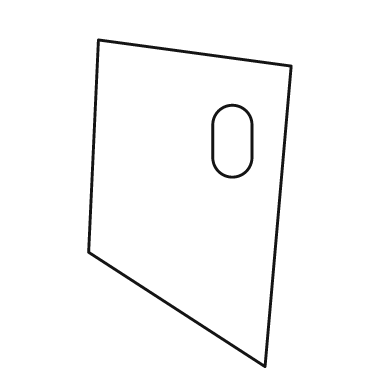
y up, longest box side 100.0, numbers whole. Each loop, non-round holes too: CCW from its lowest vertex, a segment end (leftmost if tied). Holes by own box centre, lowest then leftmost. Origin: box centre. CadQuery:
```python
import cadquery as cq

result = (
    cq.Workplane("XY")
    .moveTo(23.0, -50.0)
    .lineTo(31.0, 42.0)
    .lineTo(-28.0, 50.0)
    .lineTo(-31.0, -15.0)
    .close()
    .moveTo(7.0, 14.0)
    .threePointArc((13.0, 8.0), (19.0, 14.0))
    .lineTo(19.0, 24.0)
    .threePointArc((13.0, 30.0), (7.0, 24.0))
    .close()
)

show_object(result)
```